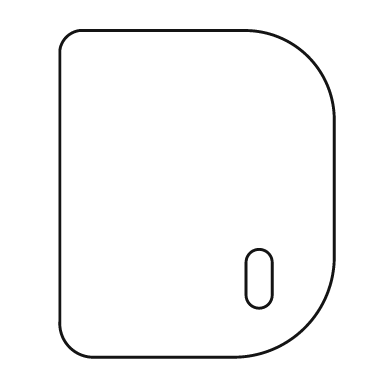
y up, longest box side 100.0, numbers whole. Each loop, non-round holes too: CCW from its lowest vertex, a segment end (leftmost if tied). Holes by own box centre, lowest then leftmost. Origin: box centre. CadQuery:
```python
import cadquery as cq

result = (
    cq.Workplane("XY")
    .moveTo(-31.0, -50.0)
    .lineTo(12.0, -50.0)
    .threePointArc((33.0, -41.0), (42.0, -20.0))
    .lineTo(42.0, 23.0)
    .threePointArc((34.0, 42.0), (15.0, 50.0))
    .lineTo(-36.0, 50.0)
    .threePointArc((-40.0, 48.0), (-42.0, 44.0))
    .lineTo(-42.0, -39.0)
    .threePointArc((-39.0, -47.0), (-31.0, -50.0))
    .close()
    .moveTo(15.0, -31.0)
    .threePointArc((19.0, -35.0), (23.0, -31.0))
    .lineTo(23.0, -21.0)
    .threePointArc((19.0, -17.0), (15.0, -21.0))
    .close()
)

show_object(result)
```